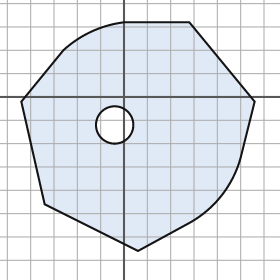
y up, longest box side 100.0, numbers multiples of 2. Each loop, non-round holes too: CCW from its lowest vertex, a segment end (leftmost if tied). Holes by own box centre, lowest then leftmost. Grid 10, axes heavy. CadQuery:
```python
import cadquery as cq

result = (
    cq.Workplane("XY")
    .moveTo(6.0, -66.0)
    .lineTo(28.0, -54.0)
    .threePointArc((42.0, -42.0), (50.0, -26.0))
    .lineTo(56.0, -2.0)
    .lineTo(28.0, 32.0)
    .lineTo(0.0, 32.0)
    .threePointArc((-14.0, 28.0), (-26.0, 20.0))
    .lineTo(-44.0, -2.0)
    .lineTo(-34.0, -46.0)
    .close()
    .moveTo(-4.0, -12.0)
    .circle(8.0)
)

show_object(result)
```